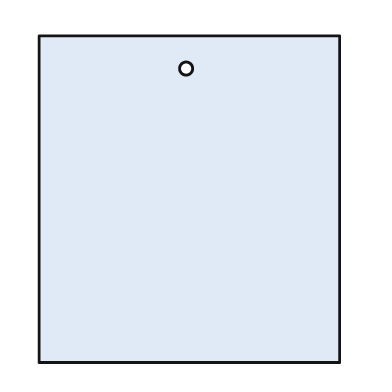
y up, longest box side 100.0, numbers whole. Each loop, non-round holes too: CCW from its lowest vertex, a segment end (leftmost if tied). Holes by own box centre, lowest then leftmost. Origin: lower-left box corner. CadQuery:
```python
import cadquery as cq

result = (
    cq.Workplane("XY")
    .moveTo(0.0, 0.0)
    .lineTo(92.0, 0.0)
    .lineTo(92.0, 100.0)
    .lineTo(0.0, 100.0)
    .close()
    .moveTo(45.0, 90.0)
    .circle(2.0)
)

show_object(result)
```